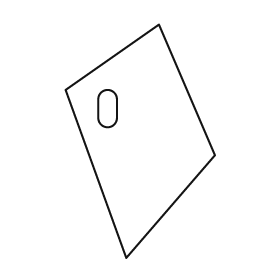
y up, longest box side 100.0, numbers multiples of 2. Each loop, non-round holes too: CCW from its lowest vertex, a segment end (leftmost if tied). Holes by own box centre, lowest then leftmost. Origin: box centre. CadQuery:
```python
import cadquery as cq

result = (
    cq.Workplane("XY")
    .moveTo(-6.0, -50.0)
    .lineTo(32.0, -6.0)
    .lineTo(8.0, 50.0)
    .lineTo(-32.0, 22.0)
    .close()
    .moveTo(-18.0, 10.0)
    .threePointArc((-14.0, 6.0), (-10.0, 10.0))
    .lineTo(-10.0, 18.0)
    .threePointArc((-14.0, 22.0), (-18.0, 18.0))
    .close()
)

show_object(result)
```